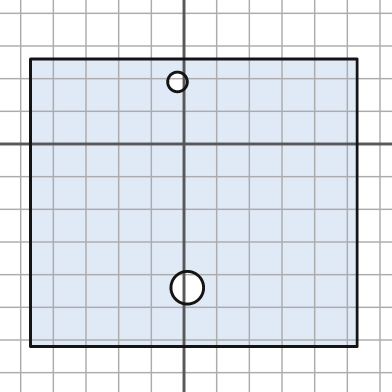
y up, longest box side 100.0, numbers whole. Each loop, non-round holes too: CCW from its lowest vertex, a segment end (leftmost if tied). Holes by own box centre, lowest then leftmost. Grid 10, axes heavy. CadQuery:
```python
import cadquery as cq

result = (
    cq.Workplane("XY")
    .moveTo(-47.0, -62.0)
    .lineTo(53.0, -62.0)
    .lineTo(53.0, 26.0)
    .lineTo(-47.0, 26.0)
    .close()
    .moveTo(1.0, -44.0)
    .circle(5.0)
    .moveTo(-2.0, 19.0)
    .circle(3.0)
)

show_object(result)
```